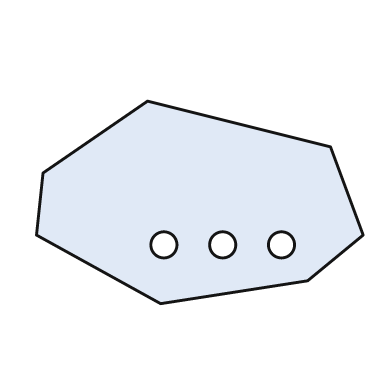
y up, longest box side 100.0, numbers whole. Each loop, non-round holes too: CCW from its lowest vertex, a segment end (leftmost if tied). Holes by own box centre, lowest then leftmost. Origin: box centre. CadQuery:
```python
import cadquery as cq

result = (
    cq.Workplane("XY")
    .moveTo(-12.0, -31.0)
    .lineTo(33.0, -24.0)
    .lineTo(50.0, -10.0)
    .lineTo(40.0, 17.0)
    .lineTo(-16.0, 31.0)
    .lineTo(-48.0, 9.0)
    .lineTo(-50.0, -10.0)
    .close()
    .moveTo(-11.0, -13.0)
    .circle(4.0)
    .moveTo(7.0, -13.0)
    .circle(4.0)
    .moveTo(25.0, -13.0)
    .circle(4.0)
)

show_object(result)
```